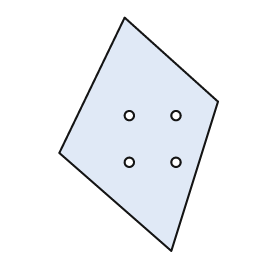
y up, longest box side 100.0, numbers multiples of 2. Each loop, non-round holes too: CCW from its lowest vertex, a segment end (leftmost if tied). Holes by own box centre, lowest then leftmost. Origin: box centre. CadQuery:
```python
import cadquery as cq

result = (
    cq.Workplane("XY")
    .moveTo(14.0, -50.0)
    .lineTo(34.0, 14.0)
    .lineTo(-6.0, 50.0)
    .lineTo(-34.0, -8.0)
    .close()
    .moveTo(-4.0, -12.0)
    .circle(2.0)
    .moveTo(16.0, -12.0)
    .circle(2.0)
    .moveTo(-4.0, 8.0)
    .circle(2.0)
    .moveTo(16.0, 8.0)
    .circle(2.0)
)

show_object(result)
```